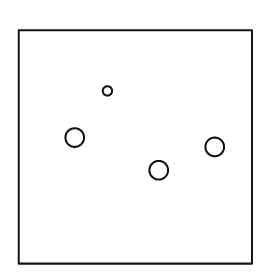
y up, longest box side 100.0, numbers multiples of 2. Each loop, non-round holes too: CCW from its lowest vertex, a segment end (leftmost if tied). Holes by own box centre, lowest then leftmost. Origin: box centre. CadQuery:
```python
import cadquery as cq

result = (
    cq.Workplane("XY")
    .moveTo(-50.0, -50.0)
    .lineTo(50.0, -50.0)
    .lineTo(50.0, 50.0)
    .lineTo(-50.0, 50.0)
    .close()
    .moveTo(10.0, -10.0)
    .circle(4.0)
    .moveTo(34.0, 0.0)
    .circle(4.0)
    .moveTo(-26.0, 4.0)
    .circle(4.0)
    .moveTo(-12.0, 24.0)
    .circle(2.0)
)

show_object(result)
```